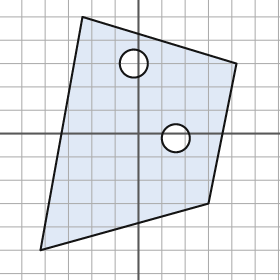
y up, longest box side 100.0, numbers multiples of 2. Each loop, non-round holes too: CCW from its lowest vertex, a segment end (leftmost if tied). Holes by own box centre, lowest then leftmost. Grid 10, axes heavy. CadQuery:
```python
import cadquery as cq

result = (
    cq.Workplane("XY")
    .moveTo(-42.0, -50.0)
    .lineTo(30.0, -30.0)
    .lineTo(42.0, 30.0)
    .lineTo(-24.0, 50.0)
    .close()
    .moveTo(16.0, -2.0)
    .circle(6.0)
    .moveTo(-2.0, 30.0)
    .circle(6.0)
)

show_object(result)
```